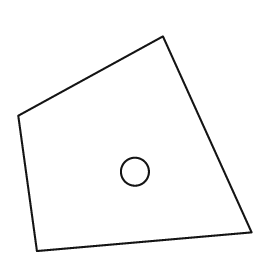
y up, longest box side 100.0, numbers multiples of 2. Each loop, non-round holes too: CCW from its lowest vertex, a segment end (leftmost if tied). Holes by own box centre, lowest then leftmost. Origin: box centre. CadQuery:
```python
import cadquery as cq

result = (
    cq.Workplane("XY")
    .moveTo(-42.0, -46.0)
    .lineTo(50.0, -38.0)
    .lineTo(12.0, 46.0)
    .lineTo(-50.0, 12.0)
    .close()
    .moveTo(0.0, -12.0)
    .circle(6.0)
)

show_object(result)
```